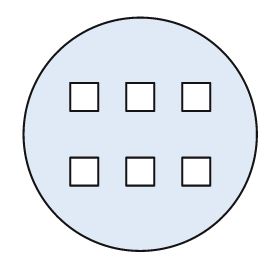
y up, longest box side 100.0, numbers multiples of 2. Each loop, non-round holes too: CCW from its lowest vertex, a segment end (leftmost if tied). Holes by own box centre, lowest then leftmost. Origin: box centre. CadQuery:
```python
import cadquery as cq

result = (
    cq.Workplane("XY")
    .moveTo(0.0, 0.0)
    .circle(50.0)
    .moveTo(-30.0, -22.0)
    .lineTo(-18.0, -22.0)
    .lineTo(-18.0, -10.0)
    .lineTo(-30.0, -10.0)
    .close()
    .moveTo(-6.0, -22.0)
    .lineTo(6.0, -22.0)
    .lineTo(6.0, -10.0)
    .lineTo(-6.0, -10.0)
    .close()
    .moveTo(18.0, -22.0)
    .lineTo(30.0, -22.0)
    .lineTo(30.0, -10.0)
    .lineTo(18.0, -10.0)
    .close()
    .moveTo(-30.0, 10.0)
    .lineTo(-18.0, 10.0)
    .lineTo(-18.0, 22.0)
    .lineTo(-30.0, 22.0)
    .close()
    .moveTo(-6.0, 10.0)
    .lineTo(6.0, 10.0)
    .lineTo(6.0, 22.0)
    .lineTo(-6.0, 22.0)
    .close()
    .moveTo(18.0, 10.0)
    .lineTo(30.0, 10.0)
    .lineTo(30.0, 22.0)
    .lineTo(18.0, 22.0)
    .close()
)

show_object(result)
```